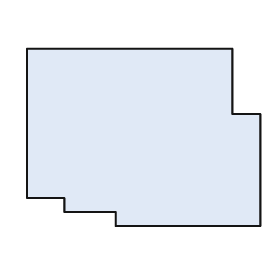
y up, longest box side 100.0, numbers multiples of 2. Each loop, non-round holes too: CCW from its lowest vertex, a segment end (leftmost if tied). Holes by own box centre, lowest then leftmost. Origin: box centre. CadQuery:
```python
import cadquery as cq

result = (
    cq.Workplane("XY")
    .moveTo(-12.0, -38.0)
    .lineTo(50.0, -38.0)
    .lineTo(50.0, 10.0)
    .lineTo(38.0, 10.0)
    .lineTo(38.0, 38.0)
    .lineTo(-50.0, 38.0)
    .lineTo(-50.0, -26.0)
    .lineTo(-34.0, -26.0)
    .lineTo(-34.0, -32.0)
    .lineTo(-12.0, -32.0)
    .close()
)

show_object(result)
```